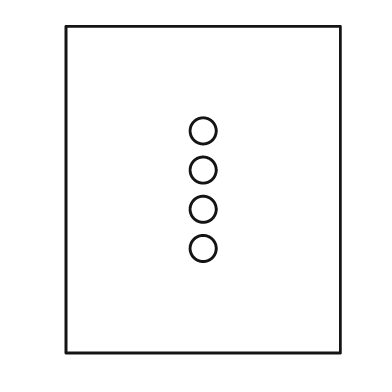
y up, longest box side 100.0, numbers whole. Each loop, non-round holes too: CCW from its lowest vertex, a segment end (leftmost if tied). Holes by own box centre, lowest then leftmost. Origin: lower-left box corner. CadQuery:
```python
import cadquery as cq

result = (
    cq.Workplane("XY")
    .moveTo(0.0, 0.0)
    .lineTo(84.0, 0.0)
    .lineTo(84.0, 100.0)
    .lineTo(0.0, 100.0)
    .close()
    .moveTo(42.0, 32.0)
    .circle(4.0)
    .moveTo(42.0, 44.0)
    .circle(4.0)
    .moveTo(42.0, 56.0)
    .circle(4.0)
    .moveTo(42.0, 68.0)
    .circle(4.0)
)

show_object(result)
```